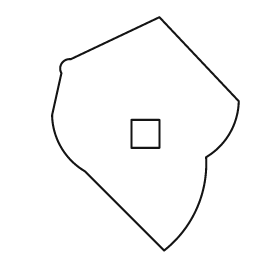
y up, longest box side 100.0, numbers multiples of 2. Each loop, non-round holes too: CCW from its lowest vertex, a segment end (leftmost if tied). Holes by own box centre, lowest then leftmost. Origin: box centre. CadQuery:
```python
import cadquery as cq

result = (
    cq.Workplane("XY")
    .moveTo(8.0, -50.0)
    .threePointArc((22.0, -32.0), (26.0, -10.0))
    .threePointArc((36.0, 0.0), (40.0, 14.0))
    .lineTo(6.0, 50.0)
    .lineTo(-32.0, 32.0)
    .threePointArc((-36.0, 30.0), (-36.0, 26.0))
    .lineTo(-40.0, 8.0)
    .threePointArc((-36.0, -6.0), (-26.0, -16.0))
    .close()
    .moveTo(-6.0, -6.0)
    .lineTo(6.0, -6.0)
    .lineTo(6.0, 6.0)
    .lineTo(-6.0, 6.0)
    .close()
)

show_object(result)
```